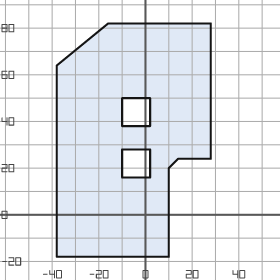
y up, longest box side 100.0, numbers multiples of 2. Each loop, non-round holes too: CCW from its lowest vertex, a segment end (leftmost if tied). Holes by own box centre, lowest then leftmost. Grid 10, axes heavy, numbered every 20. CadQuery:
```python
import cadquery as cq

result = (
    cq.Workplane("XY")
    .moveTo(-38.0, -18.0)
    .lineTo(10.0, -18.0)
    .lineTo(10.0, 20.0)
    .lineTo(14.0, 24.0)
    .lineTo(28.0, 24.0)
    .lineTo(28.0, 82.0)
    .lineTo(-16.0, 82.0)
    .lineTo(-38.0, 64.0)
    .close()
    .moveTo(-10.0, 16.0)
    .lineTo(2.0, 16.0)
    .lineTo(2.0, 28.0)
    .lineTo(-10.0, 28.0)
    .close()
    .moveTo(-10.0, 38.0)
    .lineTo(2.0, 38.0)
    .lineTo(2.0, 50.0)
    .lineTo(-10.0, 50.0)
    .close()
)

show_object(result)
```